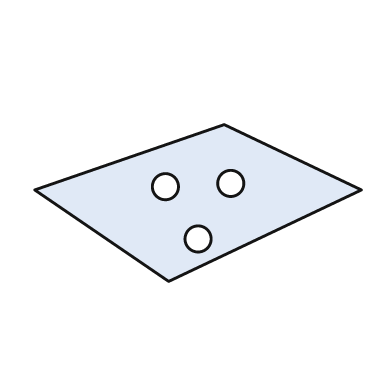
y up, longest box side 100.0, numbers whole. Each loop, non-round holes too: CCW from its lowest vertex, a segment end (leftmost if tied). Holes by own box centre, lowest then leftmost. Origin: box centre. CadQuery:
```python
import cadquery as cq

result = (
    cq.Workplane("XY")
    .moveTo(-9.0, -24.0)
    .lineTo(50.0, 4.0)
    .lineTo(8.0, 24.0)
    .lineTo(-50.0, 4.0)
    .close()
    .moveTo(0.0, -11.0)
    .circle(4.0)
    .moveTo(-10.0, 5.0)
    .circle(4.0)
    .moveTo(10.0, 6.0)
    .circle(4.0)
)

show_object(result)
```